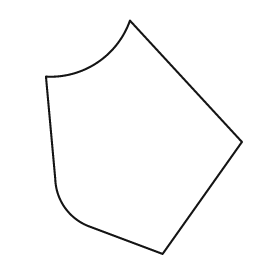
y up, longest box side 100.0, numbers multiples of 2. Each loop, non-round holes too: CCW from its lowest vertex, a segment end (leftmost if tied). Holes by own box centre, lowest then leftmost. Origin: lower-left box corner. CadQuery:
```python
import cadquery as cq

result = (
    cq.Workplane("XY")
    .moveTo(50.0, 0.0)
    .lineTo(84.0, 48.0)
    .lineTo(36.0, 100.0)
    .threePointArc((22.0, 82.0), (0.0, 76.0))
    .lineTo(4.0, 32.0)
    .threePointArc((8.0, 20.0), (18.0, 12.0))
    .close()
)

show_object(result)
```